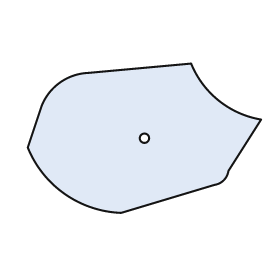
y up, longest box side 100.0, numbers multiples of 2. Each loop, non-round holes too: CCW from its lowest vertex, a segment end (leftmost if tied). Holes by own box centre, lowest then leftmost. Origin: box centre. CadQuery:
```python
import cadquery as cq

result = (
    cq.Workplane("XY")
    .moveTo(-10.0, -32.0)
    .lineTo(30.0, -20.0)
    .threePointArc((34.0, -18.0), (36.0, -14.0))
    .lineTo(50.0, 8.0)
    .threePointArc((32.0, 16.0), (20.0, 32.0))
    .lineTo(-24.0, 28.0)
    .threePointArc((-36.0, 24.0), (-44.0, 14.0))
    .lineTo(-50.0, -4.0)
    .threePointArc((-34.0, -24.0), (-10.0, -32.0))
    .close()
    .moveTo(0.0, 0.0)
    .circle(2.0)
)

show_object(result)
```